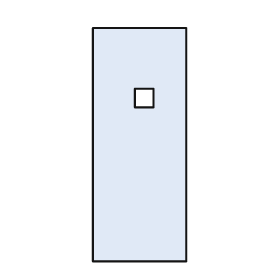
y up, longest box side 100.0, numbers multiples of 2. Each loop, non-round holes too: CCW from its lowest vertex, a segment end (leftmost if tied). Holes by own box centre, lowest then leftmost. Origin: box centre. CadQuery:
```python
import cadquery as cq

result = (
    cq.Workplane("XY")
    .moveTo(-20.0, -50.0)
    .lineTo(20.0, -50.0)
    .lineTo(20.0, 50.0)
    .lineTo(-20.0, 50.0)
    .close()
    .moveTo(-2.0, 16.0)
    .lineTo(6.0, 16.0)
    .lineTo(6.0, 24.0)
    .lineTo(-2.0, 24.0)
    .close()
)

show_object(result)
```